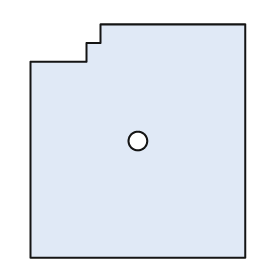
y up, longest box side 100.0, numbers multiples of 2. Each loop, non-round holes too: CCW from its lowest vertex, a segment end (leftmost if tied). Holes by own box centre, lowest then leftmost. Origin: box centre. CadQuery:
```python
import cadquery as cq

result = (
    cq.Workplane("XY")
    .moveTo(-46.0, -50.0)
    .lineTo(46.0, -50.0)
    .lineTo(46.0, 50.0)
    .lineTo(-16.0, 50.0)
    .lineTo(-16.0, 42.0)
    .lineTo(-22.0, 42.0)
    .lineTo(-22.0, 34.0)
    .lineTo(-46.0, 34.0)
    .close()
    .moveTo(0.0, 0.0)
    .circle(4.0)
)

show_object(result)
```